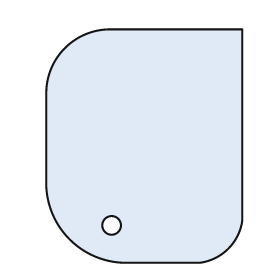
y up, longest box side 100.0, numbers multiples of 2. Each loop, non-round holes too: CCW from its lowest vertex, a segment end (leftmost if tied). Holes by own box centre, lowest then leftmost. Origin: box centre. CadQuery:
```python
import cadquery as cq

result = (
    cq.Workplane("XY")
    .moveTo(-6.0, -50.0)
    .lineTo(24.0, -50.0)
    .threePointArc((36.0, -44.0), (42.0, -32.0))
    .lineTo(42.0, 50.0)
    .lineTo(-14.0, 50.0)
    .threePointArc((-34.0, 42.0), (-42.0, 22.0))
    .lineTo(-42.0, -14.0)
    .threePointArc((-32.0, -40.0), (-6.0, -50.0))
    .close()
    .moveTo(-14.0, -34.0)
    .circle(4.0)
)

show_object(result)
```